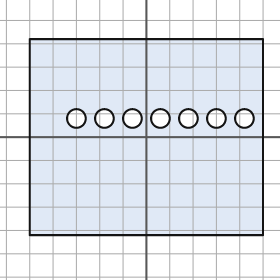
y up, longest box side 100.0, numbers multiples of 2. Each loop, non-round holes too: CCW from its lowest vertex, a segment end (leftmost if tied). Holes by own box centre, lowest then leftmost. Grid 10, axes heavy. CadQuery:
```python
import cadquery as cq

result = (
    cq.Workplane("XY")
    .moveTo(-50.0, -42.0)
    .lineTo(50.0, -42.0)
    .lineTo(50.0, 42.0)
    .lineTo(-50.0, 42.0)
    .close()
    .moveTo(-30.0, 8.0)
    .circle(4.0)
    .moveTo(-18.0, 8.0)
    .circle(4.0)
    .moveTo(-6.0, 8.0)
    .circle(4.0)
    .moveTo(6.0, 8.0)
    .circle(4.0)
    .moveTo(18.0, 8.0)
    .circle(4.0)
    .moveTo(30.0, 8.0)
    .circle(4.0)
    .moveTo(42.0, 8.0)
    .circle(4.0)
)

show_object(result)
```